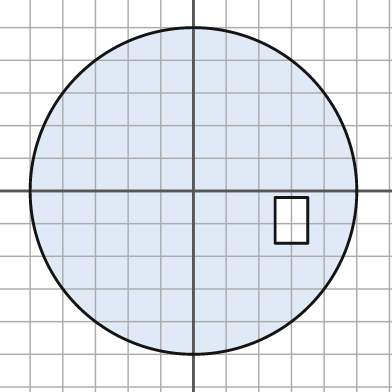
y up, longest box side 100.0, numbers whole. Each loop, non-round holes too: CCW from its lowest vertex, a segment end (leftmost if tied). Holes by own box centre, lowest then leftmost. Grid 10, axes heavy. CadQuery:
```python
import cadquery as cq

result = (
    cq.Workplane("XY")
    .moveTo(0.0, 0.0)
    .circle(50.0)
    .moveTo(25.0, -16.0)
    .lineTo(35.0, -16.0)
    .lineTo(35.0, -2.0)
    .lineTo(25.0, -2.0)
    .close()
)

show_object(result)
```